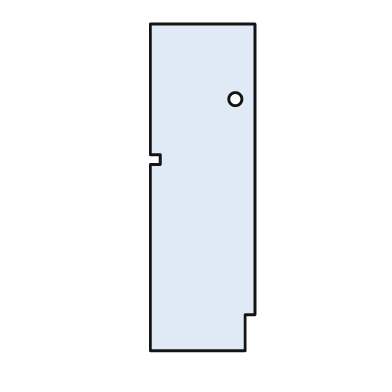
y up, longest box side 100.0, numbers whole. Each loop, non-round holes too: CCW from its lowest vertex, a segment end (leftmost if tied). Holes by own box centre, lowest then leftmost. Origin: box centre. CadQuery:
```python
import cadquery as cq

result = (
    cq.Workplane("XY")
    .moveTo(-16.0, -50.0)
    .lineTo(13.0, -50.0)
    .lineTo(13.0, -39.0)
    .lineTo(16.0, -39.0)
    .lineTo(16.0, 50.0)
    .lineTo(-16.0, 50.0)
    .lineTo(-16.0, 10.0)
    .lineTo(-13.0, 10.0)
    .lineTo(-13.0, 7.0)
    .lineTo(-16.0, 7.0)
    .close()
    .moveTo(10.0, 27.0)
    .circle(2.0)
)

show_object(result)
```